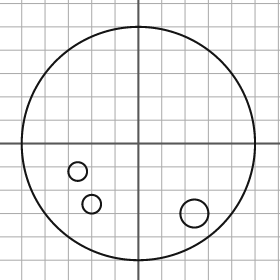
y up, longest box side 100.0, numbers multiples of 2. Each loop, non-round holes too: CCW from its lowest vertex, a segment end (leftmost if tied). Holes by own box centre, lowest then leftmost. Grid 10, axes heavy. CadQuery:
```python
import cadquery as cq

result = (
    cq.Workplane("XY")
    .moveTo(0.0, 0.0)
    .circle(50.0)
    .moveTo(24.0, -30.0)
    .circle(6.0)
    .moveTo(-20.0, -26.0)
    .circle(4.0)
    .moveTo(-26.0, -12.0)
    .circle(4.0)
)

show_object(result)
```